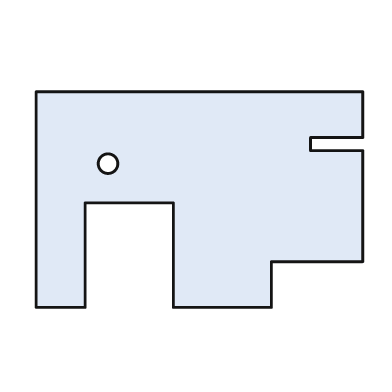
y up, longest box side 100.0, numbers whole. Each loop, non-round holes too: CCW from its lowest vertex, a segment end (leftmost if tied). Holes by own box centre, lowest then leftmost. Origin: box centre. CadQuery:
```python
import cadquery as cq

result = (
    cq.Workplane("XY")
    .moveTo(-50.0, -33.0)
    .lineTo(-35.0, -33.0)
    .lineTo(-35.0, -1.0)
    .lineTo(-8.0, -1.0)
    .lineTo(-8.0, -33.0)
    .lineTo(22.0, -33.0)
    .lineTo(22.0, -19.0)
    .lineTo(50.0, -19.0)
    .lineTo(50.0, 15.0)
    .lineTo(34.0, 15.0)
    .lineTo(34.0, 19.0)
    .lineTo(50.0, 19.0)
    .lineTo(50.0, 33.0)
    .lineTo(-50.0, 33.0)
    .close()
    .moveTo(-28.0, 11.0)
    .circle(3.0)
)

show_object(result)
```